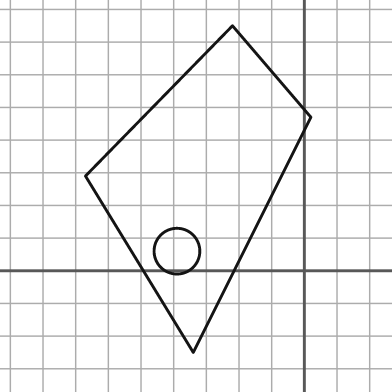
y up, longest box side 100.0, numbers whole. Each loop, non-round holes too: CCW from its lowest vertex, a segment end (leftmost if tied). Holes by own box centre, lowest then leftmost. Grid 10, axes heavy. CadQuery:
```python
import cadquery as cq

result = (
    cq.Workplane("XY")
    .moveTo(-34.0, -25.0)
    .lineTo(2.0, 47.0)
    .lineTo(-22.0, 75.0)
    .lineTo(-67.0, 29.0)
    .close()
    .moveTo(-39.0, 6.0)
    .circle(7.0)
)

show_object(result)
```